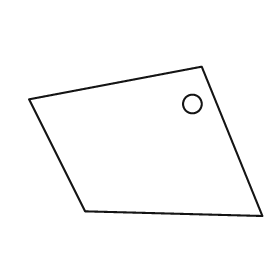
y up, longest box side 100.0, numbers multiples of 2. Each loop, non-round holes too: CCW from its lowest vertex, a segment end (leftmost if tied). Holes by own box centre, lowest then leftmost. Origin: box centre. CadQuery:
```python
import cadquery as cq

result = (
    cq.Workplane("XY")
    .moveTo(50.0, -32.0)
    .lineTo(24.0, 32.0)
    .lineTo(-50.0, 18.0)
    .lineTo(-26.0, -30.0)
    .close()
    .moveTo(20.0, 16.0)
    .circle(4.0)
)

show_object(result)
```